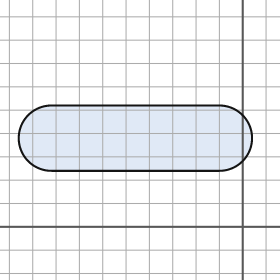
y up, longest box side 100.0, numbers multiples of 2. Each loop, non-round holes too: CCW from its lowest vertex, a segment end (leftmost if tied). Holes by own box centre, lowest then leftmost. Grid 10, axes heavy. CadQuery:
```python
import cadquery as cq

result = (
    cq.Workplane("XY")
    .moveTo(-82.0, 24.0)
    .lineTo(-10.0, 24.0)
    .threePointArc((4.0, 38.0), (-10.0, 52.0))
    .lineTo(-82.0, 52.0)
    .threePointArc((-96.0, 38.0), (-82.0, 24.0))
    .close()
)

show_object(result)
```